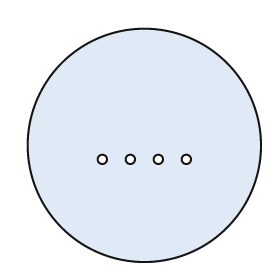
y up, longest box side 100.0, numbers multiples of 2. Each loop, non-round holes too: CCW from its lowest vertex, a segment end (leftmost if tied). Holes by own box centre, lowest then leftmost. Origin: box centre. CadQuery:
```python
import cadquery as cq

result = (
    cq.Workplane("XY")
    .moveTo(0.0, 0.0)
    .circle(50.0)
    .moveTo(-18.0, -6.0)
    .circle(2.0)
    .moveTo(-6.0, -6.0)
    .circle(2.0)
    .moveTo(6.0, -6.0)
    .circle(2.0)
    .moveTo(18.0, -6.0)
    .circle(2.0)
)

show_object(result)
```